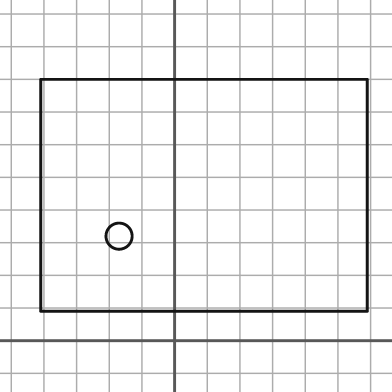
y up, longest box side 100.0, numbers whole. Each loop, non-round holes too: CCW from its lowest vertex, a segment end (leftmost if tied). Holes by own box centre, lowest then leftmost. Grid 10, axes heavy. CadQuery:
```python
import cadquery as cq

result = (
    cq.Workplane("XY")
    .moveTo(-41.0, 9.0)
    .lineTo(59.0, 9.0)
    .lineTo(59.0, 80.0)
    .lineTo(-41.0, 80.0)
    .close()
    .moveTo(-17.0, 32.0)
    .circle(4.0)
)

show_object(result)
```